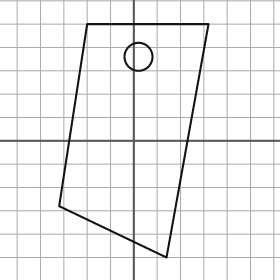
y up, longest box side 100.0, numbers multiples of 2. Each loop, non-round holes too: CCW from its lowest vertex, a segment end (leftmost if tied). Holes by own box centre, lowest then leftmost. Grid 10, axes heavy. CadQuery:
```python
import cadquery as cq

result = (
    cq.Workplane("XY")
    .moveTo(14.0, -50.0)
    .lineTo(32.0, 50.0)
    .lineTo(-20.0, 50.0)
    .lineTo(-32.0, -28.0)
    .close()
    .moveTo(2.0, 36.0)
    .circle(6.0)
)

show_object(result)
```